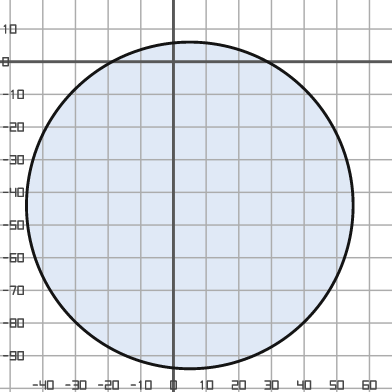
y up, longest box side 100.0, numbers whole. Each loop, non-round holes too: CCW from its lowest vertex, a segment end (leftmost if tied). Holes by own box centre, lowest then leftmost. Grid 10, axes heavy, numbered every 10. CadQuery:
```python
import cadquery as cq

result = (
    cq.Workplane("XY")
    .moveTo(5.0, -44.0)
    .circle(50.0)
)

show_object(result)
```